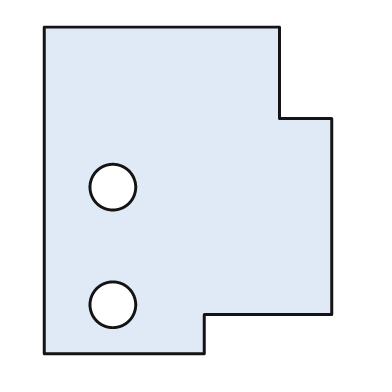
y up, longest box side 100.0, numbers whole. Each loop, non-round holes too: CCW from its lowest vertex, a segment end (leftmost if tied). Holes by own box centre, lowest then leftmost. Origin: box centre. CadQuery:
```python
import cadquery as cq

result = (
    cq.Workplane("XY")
    .moveTo(-44.0, -50.0)
    .lineTo(5.0, -50.0)
    .lineTo(5.0, -38.0)
    .lineTo(44.0, -38.0)
    .lineTo(44.0, 22.0)
    .lineTo(28.0, 22.0)
    .lineTo(28.0, 50.0)
    .lineTo(-44.0, 50.0)
    .close()
    .moveTo(-23.0, -35.0)
    .circle(7.0)
    .moveTo(-23.0, 1.0)
    .circle(7.0)
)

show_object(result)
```